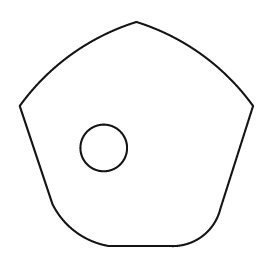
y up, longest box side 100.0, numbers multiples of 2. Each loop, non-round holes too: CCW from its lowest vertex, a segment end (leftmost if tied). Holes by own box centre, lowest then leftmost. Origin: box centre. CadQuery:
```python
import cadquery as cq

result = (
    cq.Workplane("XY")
    .moveTo(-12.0, -48.0)
    .lineTo(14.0, -48.0)
    .threePointArc((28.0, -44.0), (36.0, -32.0))
    .lineTo(50.0, 12.0)
    .threePointArc((28.0, 34.0), (0.0, 48.0))
    .threePointArc((-28.0, 34.0), (-50.0, 12.0))
    .lineTo(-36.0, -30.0)
    .threePointArc((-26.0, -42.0), (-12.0, -48.0))
    .close()
    .moveTo(-14.0, -6.0)
    .circle(10.0)
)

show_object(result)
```